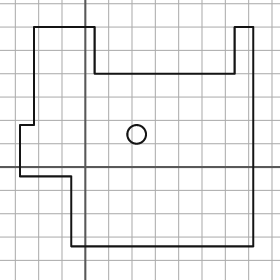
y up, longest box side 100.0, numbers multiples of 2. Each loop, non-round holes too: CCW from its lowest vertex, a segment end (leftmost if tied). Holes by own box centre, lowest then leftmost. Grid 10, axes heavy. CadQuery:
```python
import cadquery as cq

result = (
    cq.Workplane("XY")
    .moveTo(-6.0, -34.0)
    .lineTo(72.0, -34.0)
    .lineTo(72.0, 60.0)
    .lineTo(64.0, 60.0)
    .lineTo(64.0, 40.0)
    .lineTo(4.0, 40.0)
    .lineTo(4.0, 60.0)
    .lineTo(-22.0, 60.0)
    .lineTo(-22.0, 18.0)
    .lineTo(-28.0, 18.0)
    .lineTo(-28.0, -4.0)
    .lineTo(-6.0, -4.0)
    .close()
    .moveTo(22.0, 14.0)
    .circle(4.0)
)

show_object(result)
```